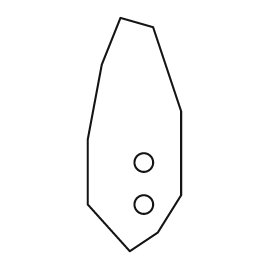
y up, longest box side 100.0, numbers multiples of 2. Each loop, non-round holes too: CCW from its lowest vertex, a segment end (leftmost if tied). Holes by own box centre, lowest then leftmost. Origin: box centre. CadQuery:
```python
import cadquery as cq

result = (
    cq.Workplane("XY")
    .moveTo(-2.0, -50.0)
    .lineTo(10.0, -42.0)
    .lineTo(20.0, -26.0)
    .lineTo(20.0, 10.0)
    .lineTo(8.0, 46.0)
    .lineTo(-6.0, 50.0)
    .lineTo(-14.0, 30.0)
    .lineTo(-20.0, -2.0)
    .lineTo(-20.0, -30.0)
    .close()
    .moveTo(4.0, -30.0)
    .circle(4.0)
    .moveTo(4.0, -12.0)
    .circle(4.0)
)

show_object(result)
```